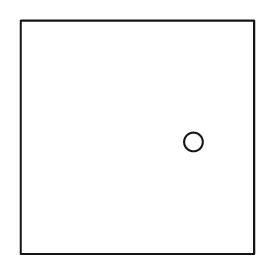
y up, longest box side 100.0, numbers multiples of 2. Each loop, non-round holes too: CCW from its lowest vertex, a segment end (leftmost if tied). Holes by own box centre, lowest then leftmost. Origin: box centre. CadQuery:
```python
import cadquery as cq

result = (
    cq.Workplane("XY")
    .moveTo(-50.0, -50.0)
    .lineTo(50.0, -50.0)
    .lineTo(50.0, 50.0)
    .lineTo(-50.0, 50.0)
    .close()
    .moveTo(24.0, -2.0)
    .circle(4.0)
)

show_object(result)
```